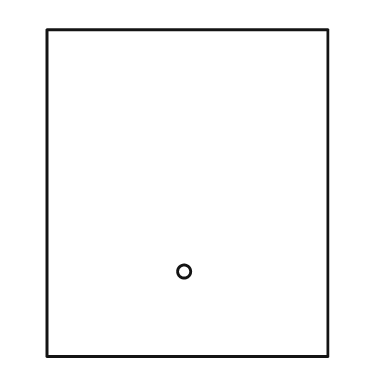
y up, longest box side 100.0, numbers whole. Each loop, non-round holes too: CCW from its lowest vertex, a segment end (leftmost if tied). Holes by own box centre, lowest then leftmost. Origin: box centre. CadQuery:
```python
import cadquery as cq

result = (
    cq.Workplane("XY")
    .moveTo(-43.0, -50.0)
    .lineTo(43.0, -50.0)
    .lineTo(43.0, 50.0)
    .lineTo(-43.0, 50.0)
    .close()
    .moveTo(-1.0, -24.0)
    .circle(2.0)
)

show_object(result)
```